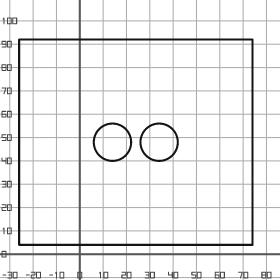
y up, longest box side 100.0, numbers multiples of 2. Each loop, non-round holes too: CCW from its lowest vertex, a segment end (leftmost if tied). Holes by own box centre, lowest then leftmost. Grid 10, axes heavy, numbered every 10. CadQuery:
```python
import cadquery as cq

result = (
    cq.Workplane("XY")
    .moveTo(-26.0, 4.0)
    .lineTo(74.0, 4.0)
    .lineTo(74.0, 92.0)
    .lineTo(-26.0, 92.0)
    .close()
    .moveTo(14.0, 48.0)
    .circle(8.0)
    .moveTo(34.0, 48.0)
    .circle(8.0)
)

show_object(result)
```